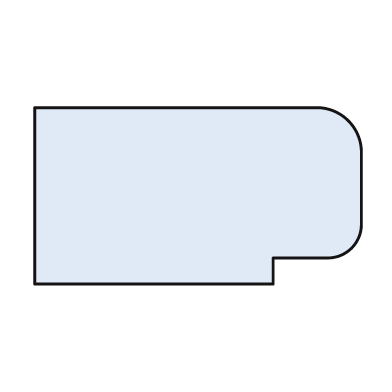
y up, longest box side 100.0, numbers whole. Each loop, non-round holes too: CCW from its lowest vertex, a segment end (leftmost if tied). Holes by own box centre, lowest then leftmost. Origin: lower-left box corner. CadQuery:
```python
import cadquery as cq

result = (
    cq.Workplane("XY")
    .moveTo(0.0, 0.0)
    .lineTo(73.0, 0.0)
    .lineTo(73.0, 8.0)
    .lineTo(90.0, 8.0)
    .threePointArc((97.0, 11.0), (100.0, 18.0))
    .lineTo(100.0, 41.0)
    .threePointArc((96.0, 50.0), (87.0, 54.0))
    .lineTo(0.0, 54.0)
    .close()
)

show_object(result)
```